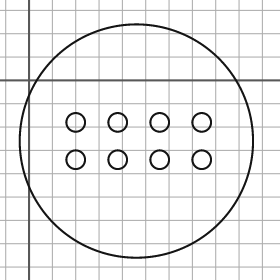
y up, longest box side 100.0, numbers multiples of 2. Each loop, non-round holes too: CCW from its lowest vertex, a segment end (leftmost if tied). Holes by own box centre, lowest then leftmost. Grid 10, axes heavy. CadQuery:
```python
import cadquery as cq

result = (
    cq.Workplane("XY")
    .moveTo(46.0, -26.0)
    .circle(50.0)
    .moveTo(20.0, -34.0)
    .circle(4.0)
    .moveTo(38.0, -34.0)
    .circle(4.0)
    .moveTo(56.0, -34.0)
    .circle(4.0)
    .moveTo(74.0, -34.0)
    .circle(4.0)
    .moveTo(20.0, -18.0)
    .circle(4.0)
    .moveTo(38.0, -18.0)
    .circle(4.0)
    .moveTo(56.0, -18.0)
    .circle(4.0)
    .moveTo(74.0, -18.0)
    .circle(4.0)
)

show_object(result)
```